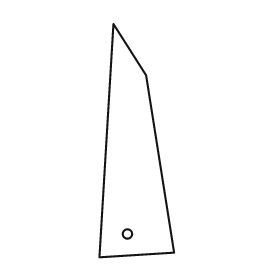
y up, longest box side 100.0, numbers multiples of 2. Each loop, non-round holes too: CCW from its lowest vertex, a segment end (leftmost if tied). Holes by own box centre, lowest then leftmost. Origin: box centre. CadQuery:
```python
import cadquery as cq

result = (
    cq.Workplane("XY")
    .moveTo(-16.0, -50.0)
    .lineTo(16.0, -48.0)
    .lineTo(4.0, 28.0)
    .lineTo(-10.0, 50.0)
    .close()
    .moveTo(-4.0, -40.0)
    .circle(2.0)
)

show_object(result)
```